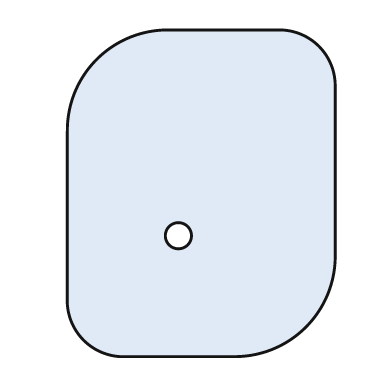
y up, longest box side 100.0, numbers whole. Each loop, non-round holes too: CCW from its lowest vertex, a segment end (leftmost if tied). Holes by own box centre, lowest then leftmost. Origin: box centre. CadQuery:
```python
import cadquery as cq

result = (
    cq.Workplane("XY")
    .moveTo(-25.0, -50.0)
    .lineTo(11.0, -50.0)
    .threePointArc((32.0, -41.0), (41.0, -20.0))
    .lineTo(41.0, 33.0)
    .threePointArc((36.0, 45.0), (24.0, 50.0))
    .lineTo(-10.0, 50.0)
    .threePointArc((-32.0, 41.0), (-41.0, 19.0))
    .lineTo(-41.0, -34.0)
    .threePointArc((-36.0, -45.0), (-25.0, -50.0))
    .close()
    .moveTo(-7.0, -13.0)
    .circle(4.0)
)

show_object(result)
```